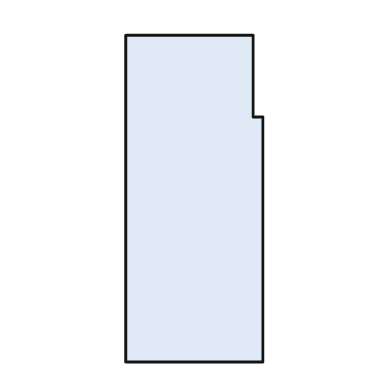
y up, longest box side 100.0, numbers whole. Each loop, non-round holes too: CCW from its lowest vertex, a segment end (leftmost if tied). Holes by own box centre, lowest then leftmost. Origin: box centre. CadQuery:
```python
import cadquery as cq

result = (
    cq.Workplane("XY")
    .moveTo(-21.0, -50.0)
    .lineTo(21.0, -50.0)
    .lineTo(21.0, 25.0)
    .lineTo(18.0, 25.0)
    .lineTo(18.0, 50.0)
    .lineTo(-21.0, 50.0)
    .close()
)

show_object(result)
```